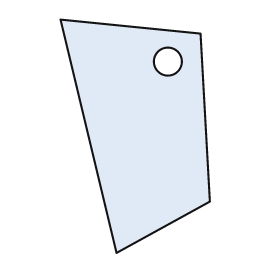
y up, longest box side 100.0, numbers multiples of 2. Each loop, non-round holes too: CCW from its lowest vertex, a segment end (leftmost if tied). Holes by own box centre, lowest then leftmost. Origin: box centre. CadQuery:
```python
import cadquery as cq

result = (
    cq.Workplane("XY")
    .moveTo(-8.0, -50.0)
    .lineTo(32.0, -28.0)
    .lineTo(28.0, 44.0)
    .lineTo(-32.0, 50.0)
    .close()
    .moveTo(14.0, 32.0)
    .circle(6.0)
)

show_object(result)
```